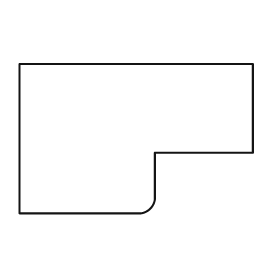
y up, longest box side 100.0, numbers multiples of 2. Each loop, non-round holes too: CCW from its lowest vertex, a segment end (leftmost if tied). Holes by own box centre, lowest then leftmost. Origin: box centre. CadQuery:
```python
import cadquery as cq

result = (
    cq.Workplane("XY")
    .moveTo(-50.0, -32.0)
    .lineTo(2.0, -32.0)
    .threePointArc((6.0, -30.0), (8.0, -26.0))
    .lineTo(8.0, -6.0)
    .lineTo(50.0, -6.0)
    .lineTo(50.0, 32.0)
    .lineTo(-50.0, 32.0)
    .close()
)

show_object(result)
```